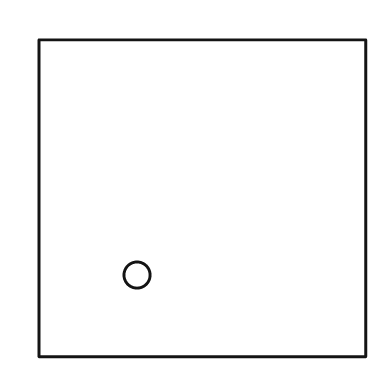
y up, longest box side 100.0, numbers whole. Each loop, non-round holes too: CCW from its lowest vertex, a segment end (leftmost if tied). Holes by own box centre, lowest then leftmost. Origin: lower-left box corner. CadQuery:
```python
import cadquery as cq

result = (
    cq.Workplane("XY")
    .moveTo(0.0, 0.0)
    .lineTo(100.0, 0.0)
    .lineTo(100.0, 97.0)
    .lineTo(0.0, 97.0)
    .close()
    .moveTo(30.0, 25.0)
    .circle(4.0)
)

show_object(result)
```